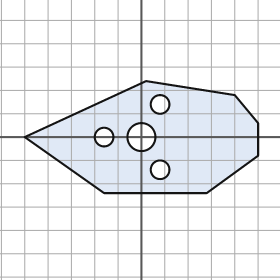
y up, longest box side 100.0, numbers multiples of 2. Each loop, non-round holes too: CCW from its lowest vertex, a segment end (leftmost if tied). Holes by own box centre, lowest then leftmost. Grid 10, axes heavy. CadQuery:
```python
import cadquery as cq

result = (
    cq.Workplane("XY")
    .moveTo(-16.0, -24.0)
    .lineTo(28.0, -24.0)
    .lineTo(50.0, -8.0)
    .lineTo(50.0, 6.0)
    .lineTo(40.0, 18.0)
    .lineTo(2.0, 24.0)
    .lineTo(-50.0, 0.0)
    .close()
    .moveTo(8.0, -14.0)
    .circle(4.0)
    .moveTo(-16.0, 0.0)
    .circle(4.0)
    .moveTo(0.0, 0.0)
    .circle(6.0)
    .moveTo(8.0, 14.0)
    .circle(4.0)
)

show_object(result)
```